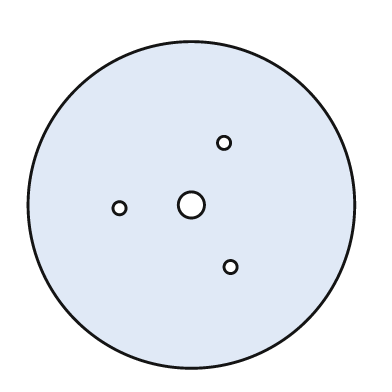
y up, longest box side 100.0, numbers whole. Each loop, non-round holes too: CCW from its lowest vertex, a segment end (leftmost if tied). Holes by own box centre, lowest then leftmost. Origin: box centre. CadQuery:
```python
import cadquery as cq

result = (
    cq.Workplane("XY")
    .moveTo(0.0, 0.0)
    .circle(50.0)
    .moveTo(12.0, -19.0)
    .circle(2.0)
    .moveTo(-22.0, -1.0)
    .circle(2.0)
    .moveTo(0.0, 0.0)
    .circle(4.0)
    .moveTo(10.0, 19.0)
    .circle(2.0)
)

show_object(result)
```